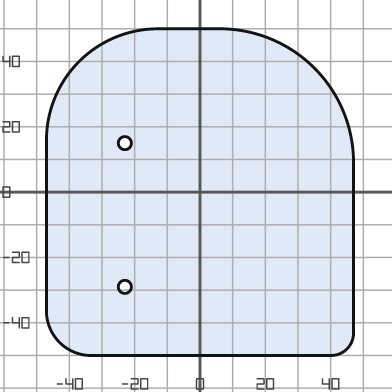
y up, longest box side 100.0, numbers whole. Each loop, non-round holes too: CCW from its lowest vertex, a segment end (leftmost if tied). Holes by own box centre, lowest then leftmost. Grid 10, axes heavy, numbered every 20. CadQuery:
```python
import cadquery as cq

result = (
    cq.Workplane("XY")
    .moveTo(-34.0, -50.0)
    .lineTo(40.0, -50.0)
    .threePointArc((45.0, -48.0), (47.0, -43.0))
    .lineTo(47.0, 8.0)
    .threePointArc((35.0, 38.0), (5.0, 50.0))
    .lineTo(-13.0, 50.0)
    .threePointArc((-37.0, 40.0), (-47.0, 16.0))
    .lineTo(-47.0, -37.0)
    .threePointArc((-43.0, -46.0), (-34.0, -50.0))
    .close()
    .moveTo(-23.0, -29.0)
    .circle(2.0)
    .moveTo(-23.0, 15.0)
    .circle(2.0)
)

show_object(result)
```